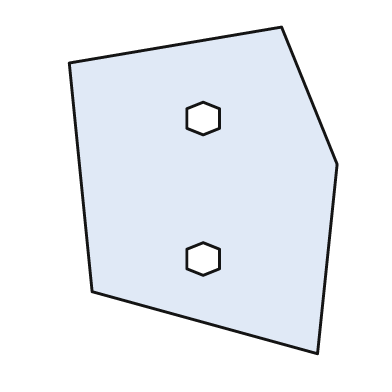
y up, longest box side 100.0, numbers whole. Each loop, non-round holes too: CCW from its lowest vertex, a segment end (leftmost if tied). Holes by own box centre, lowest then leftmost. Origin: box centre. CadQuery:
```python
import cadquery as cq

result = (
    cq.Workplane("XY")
    .moveTo(35.0, -50.0)
    .lineTo(41.0, 8.0)
    .lineTo(24.0, 50.0)
    .lineTo(-41.0, 39.0)
    .lineTo(-34.0, -31.0)
    .close()
    .moveTo(0.0, -26.0)
    .lineTo(5.0, -24.0)
    .lineTo(5.0, -18.0)
    .lineTo(0.0, -16.0)
    .lineTo(-5.0, -18.0)
    .lineTo(-5.0, -24.0)
    .close()
    .moveTo(0.0, 17.0)
    .lineTo(5.0, 19.0)
    .lineTo(5.0, 25.0)
    .lineTo(0.0, 27.0)
    .lineTo(-5.0, 25.0)
    .lineTo(-5.0, 19.0)
    .close()
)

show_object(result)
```